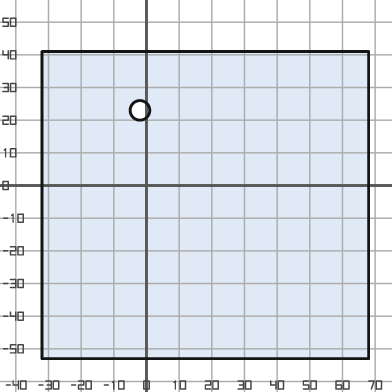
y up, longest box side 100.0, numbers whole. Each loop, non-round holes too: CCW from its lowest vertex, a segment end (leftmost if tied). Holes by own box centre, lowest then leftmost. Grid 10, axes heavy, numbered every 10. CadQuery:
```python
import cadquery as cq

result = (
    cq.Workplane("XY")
    .moveTo(-32.0, -53.0)
    .lineTo(68.0, -53.0)
    .lineTo(68.0, 41.0)
    .lineTo(-32.0, 41.0)
    .close()
    .moveTo(-2.0, 23.0)
    .circle(3.0)
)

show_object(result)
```